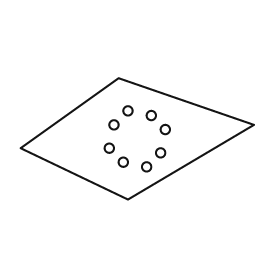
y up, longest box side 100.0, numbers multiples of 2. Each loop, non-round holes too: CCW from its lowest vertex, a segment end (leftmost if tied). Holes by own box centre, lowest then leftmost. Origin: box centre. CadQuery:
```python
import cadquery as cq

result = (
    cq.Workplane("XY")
    .moveTo(-4.0, -26.0)
    .lineTo(50.0, 6.0)
    .lineTo(-8.0, 26.0)
    .lineTo(-50.0, -4.0)
    .close()
    .moveTo(4.0, -12.0)
    .circle(2.0)
    .moveTo(-6.0, -10.0)
    .circle(2.0)
    .moveTo(10.0, -6.0)
    .circle(2.0)
    .moveTo(-12.0, -4.0)
    .circle(2.0)
    .moveTo(12.0, 4.0)
    .circle(2.0)
    .moveTo(-10.0, 6.0)
    .circle(2.0)
    .moveTo(6.0, 10.0)
    .circle(2.0)
    .moveTo(-4.0, 12.0)
    .circle(2.0)
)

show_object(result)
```